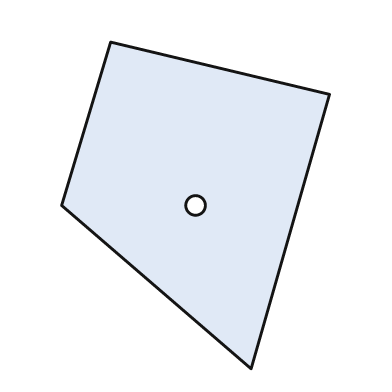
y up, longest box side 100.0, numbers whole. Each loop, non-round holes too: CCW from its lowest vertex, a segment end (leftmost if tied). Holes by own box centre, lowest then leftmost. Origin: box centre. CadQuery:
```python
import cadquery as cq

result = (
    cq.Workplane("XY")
    .moveTo(17.0, -50.0)
    .lineTo(41.0, 34.0)
    .lineTo(-26.0, 50.0)
    .lineTo(-41.0, 0.0)
    .close()
    .moveTo(0.0, 0.0)
    .circle(3.0)
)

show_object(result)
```